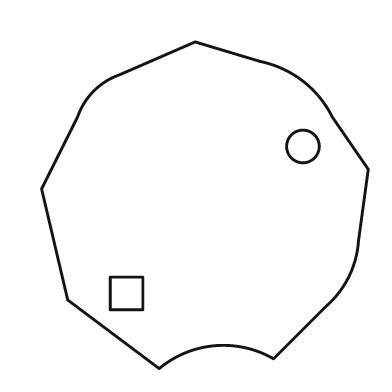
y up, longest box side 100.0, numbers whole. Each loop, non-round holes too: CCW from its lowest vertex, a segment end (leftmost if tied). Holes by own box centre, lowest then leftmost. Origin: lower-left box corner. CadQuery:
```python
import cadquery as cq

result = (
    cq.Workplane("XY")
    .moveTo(36.0, 0.0)
    .threePointArc((53.0, 7.0), (71.0, 3.0))
    .lineTo(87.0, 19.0)
    .threePointArc((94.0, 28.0), (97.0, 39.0))
    .lineTo(100.0, 61.0)
    .lineTo(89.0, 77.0)
    .threePointArc((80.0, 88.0), (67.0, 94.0))
    .lineTo(47.0, 100.0)
    .lineTo(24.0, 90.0)
    .threePointArc((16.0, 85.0), (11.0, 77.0))
    .lineTo(0.0, 55.0)
    .lineTo(8.0, 21.0)
    .close()
    .moveTo(21.0, 18.0)
    .lineTo(31.0, 18.0)
    .lineTo(31.0, 28.0)
    .lineTo(21.0, 28.0)
    .close()
    .moveTo(80.0, 68.0)
    .circle(5.0)
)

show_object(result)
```